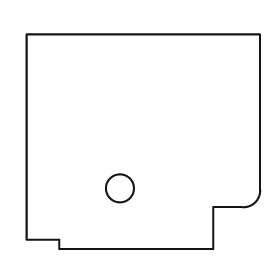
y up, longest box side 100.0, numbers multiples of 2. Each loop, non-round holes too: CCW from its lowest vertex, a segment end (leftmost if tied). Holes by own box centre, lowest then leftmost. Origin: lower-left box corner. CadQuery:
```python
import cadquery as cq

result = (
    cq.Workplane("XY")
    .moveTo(14.0, 0.0)
    .lineTo(80.0, 0.0)
    .lineTo(80.0, 18.0)
    .lineTo(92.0, 18.0)
    .threePointArc((98.0, 20.0), (100.0, 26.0))
    .lineTo(100.0, 92.0)
    .lineTo(0.0, 92.0)
    .lineTo(0.0, 4.0)
    .lineTo(14.0, 4.0)
    .close()
    .moveTo(40.0, 26.0)
    .circle(6.0)
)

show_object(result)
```